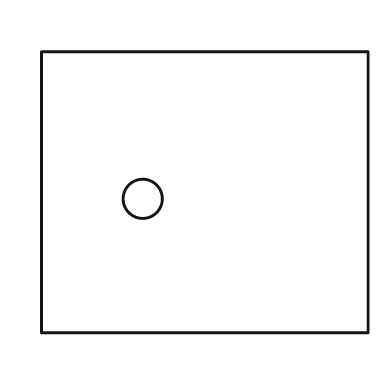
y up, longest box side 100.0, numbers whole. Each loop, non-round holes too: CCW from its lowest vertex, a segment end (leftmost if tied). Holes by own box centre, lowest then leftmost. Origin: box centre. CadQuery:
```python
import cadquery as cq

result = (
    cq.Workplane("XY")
    .moveTo(-50.0, -43.0)
    .lineTo(50.0, -43.0)
    .lineTo(50.0, 43.0)
    .lineTo(-50.0, 43.0)
    .close()
    .moveTo(-19.0, -2.0)
    .circle(6.0)
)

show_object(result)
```